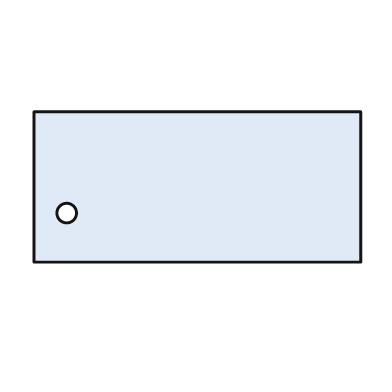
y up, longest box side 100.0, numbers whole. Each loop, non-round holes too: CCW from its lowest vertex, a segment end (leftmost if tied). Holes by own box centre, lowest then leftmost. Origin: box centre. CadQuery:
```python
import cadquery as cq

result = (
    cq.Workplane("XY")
    .moveTo(-50.0, -23.0)
    .lineTo(50.0, -23.0)
    .lineTo(50.0, 23.0)
    .lineTo(-50.0, 23.0)
    .close()
    .moveTo(-40.0, -8.0)
    .circle(3.0)
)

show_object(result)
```